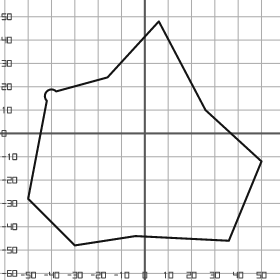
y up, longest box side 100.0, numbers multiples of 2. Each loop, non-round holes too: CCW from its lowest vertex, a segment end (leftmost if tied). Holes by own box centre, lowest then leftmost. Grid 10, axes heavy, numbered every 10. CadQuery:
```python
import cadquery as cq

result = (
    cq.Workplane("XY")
    .moveTo(-30.0, -48.0)
    .lineTo(-4.0, -44.0)
    .lineTo(36.0, -46.0)
    .lineTo(50.0, -12.0)
    .lineTo(26.0, 10.0)
    .lineTo(6.0, 48.0)
    .lineTo(-16.0, 24.0)
    .lineTo(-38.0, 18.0)
    .threePointArc((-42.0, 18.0), (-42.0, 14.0))
    .lineTo(-50.0, -28.0)
    .close()
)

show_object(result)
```